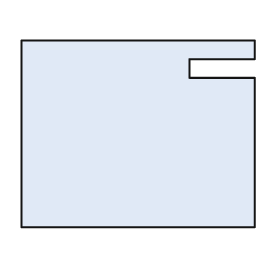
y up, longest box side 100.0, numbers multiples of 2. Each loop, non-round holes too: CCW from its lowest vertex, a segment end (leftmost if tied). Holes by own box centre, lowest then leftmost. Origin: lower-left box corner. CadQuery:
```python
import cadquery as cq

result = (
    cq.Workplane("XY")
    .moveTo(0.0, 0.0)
    .lineTo(100.0, 0.0)
    .lineTo(100.0, 64.0)
    .lineTo(72.0, 64.0)
    .lineTo(72.0, 72.0)
    .lineTo(100.0, 72.0)
    .lineTo(100.0, 80.0)
    .lineTo(0.0, 80.0)
    .close()
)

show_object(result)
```